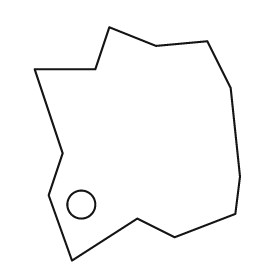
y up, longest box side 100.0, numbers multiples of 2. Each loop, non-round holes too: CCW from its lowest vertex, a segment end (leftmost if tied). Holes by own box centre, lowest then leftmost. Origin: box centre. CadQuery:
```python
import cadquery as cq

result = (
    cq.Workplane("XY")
    .moveTo(-28.0, -50.0)
    .lineTo(0.0, -32.0)
    .lineTo(16.0, -40.0)
    .lineTo(42.0, -30.0)
    .lineTo(44.0, -14.0)
    .lineTo(40.0, 24.0)
    .lineTo(30.0, 44.0)
    .lineTo(8.0, 42.0)
    .lineTo(-12.0, 50.0)
    .lineTo(-18.0, 32.0)
    .lineTo(-44.0, 32.0)
    .lineTo(-32.0, -4.0)
    .lineTo(-38.0, -22.0)
    .close()
    .moveTo(-24.0, -26.0)
    .circle(6.0)
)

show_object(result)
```